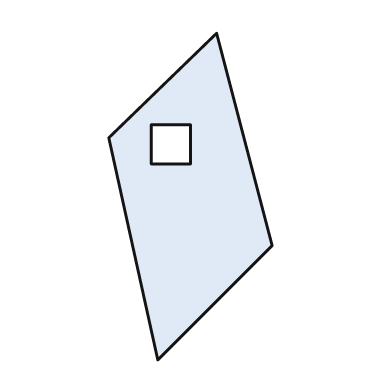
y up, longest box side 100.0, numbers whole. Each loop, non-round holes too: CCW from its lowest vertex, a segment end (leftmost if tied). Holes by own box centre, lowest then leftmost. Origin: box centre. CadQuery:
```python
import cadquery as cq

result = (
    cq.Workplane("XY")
    .moveTo(-10.0, -50.0)
    .lineTo(25.0, -15.0)
    .lineTo(8.0, 50.0)
    .lineTo(-25.0, 18.0)
    .close()
    .moveTo(-12.0, 10.0)
    .lineTo(0.0, 10.0)
    .lineTo(0.0, 22.0)
    .lineTo(-12.0, 22.0)
    .close()
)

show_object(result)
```